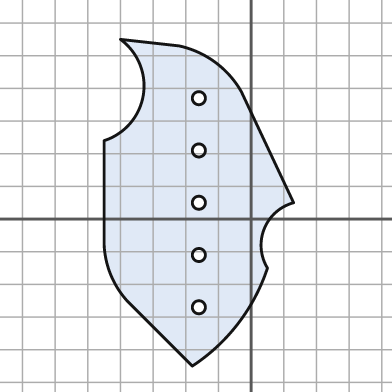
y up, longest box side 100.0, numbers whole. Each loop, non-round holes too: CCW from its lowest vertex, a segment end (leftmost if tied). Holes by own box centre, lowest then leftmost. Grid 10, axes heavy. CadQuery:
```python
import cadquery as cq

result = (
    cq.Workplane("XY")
    .moveTo(-18.0, -45.0)
    .threePointArc((-4.0, -32.0), (5.0, -15.0))
    .threePointArc((4.0, -3.0), (13.0, 5.0))
    .lineTo(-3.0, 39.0)
    .threePointArc((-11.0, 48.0), (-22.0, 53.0))
    .lineTo(-40.0, 55.0)
    .threePointArc((-33.0, 38.0), (-45.0, 24.0))
    .lineTo(-45.0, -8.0)
    .threePointArc((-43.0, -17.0), (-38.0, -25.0))
    .close()
    .moveTo(-16.0, -27.0)
    .circle(2.0)
    .moveTo(-16.0, -11.0)
    .circle(2.0)
    .moveTo(-16.0, 5.0)
    .circle(2.0)
    .moveTo(-16.0, 21.0)
    .circle(2.0)
    .moveTo(-16.0, 37.0)
    .circle(2.0)
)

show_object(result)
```